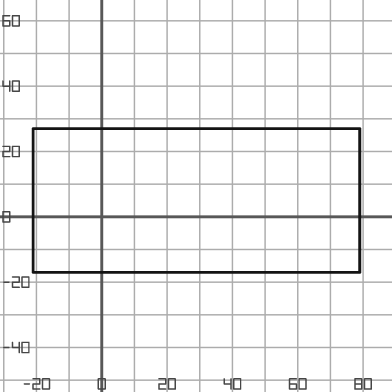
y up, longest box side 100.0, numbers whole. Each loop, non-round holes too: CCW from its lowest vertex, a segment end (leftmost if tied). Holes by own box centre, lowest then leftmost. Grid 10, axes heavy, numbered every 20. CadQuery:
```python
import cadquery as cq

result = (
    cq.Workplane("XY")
    .moveTo(-21.0, -17.0)
    .lineTo(79.0, -17.0)
    .lineTo(79.0, 27.0)
    .lineTo(-21.0, 27.0)
    .close()
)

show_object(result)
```